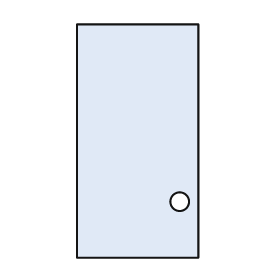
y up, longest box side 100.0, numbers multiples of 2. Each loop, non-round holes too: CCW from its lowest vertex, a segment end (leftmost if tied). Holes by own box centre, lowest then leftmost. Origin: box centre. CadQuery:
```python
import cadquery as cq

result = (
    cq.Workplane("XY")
    .moveTo(-26.0, -50.0)
    .lineTo(26.0, -50.0)
    .lineTo(26.0, 50.0)
    .lineTo(-26.0, 50.0)
    .close()
    .moveTo(18.0, -26.0)
    .circle(4.0)
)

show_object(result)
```